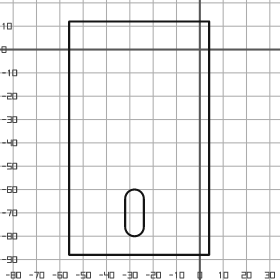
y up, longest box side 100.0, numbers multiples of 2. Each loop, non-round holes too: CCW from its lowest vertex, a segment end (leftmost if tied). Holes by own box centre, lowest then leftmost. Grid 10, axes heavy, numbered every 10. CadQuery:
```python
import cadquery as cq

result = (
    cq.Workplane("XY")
    .moveTo(-56.0, -88.0)
    .lineTo(4.0, -88.0)
    .lineTo(4.0, 12.0)
    .lineTo(-56.0, 12.0)
    .close()
    .moveTo(-32.0, -76.0)
    .threePointArc((-28.0, -80.0), (-24.0, -76.0))
    .lineTo(-24.0, -64.0)
    .threePointArc((-28.0, -60.0), (-32.0, -64.0))
    .close()
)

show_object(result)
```